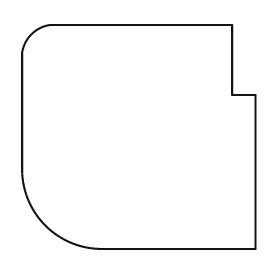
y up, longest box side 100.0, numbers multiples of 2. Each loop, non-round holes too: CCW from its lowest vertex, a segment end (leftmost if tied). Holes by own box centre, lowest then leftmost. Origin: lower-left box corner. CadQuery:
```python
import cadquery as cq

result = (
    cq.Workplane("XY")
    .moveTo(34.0, 0.0)
    .lineTo(100.0, 0.0)
    .lineTo(100.0, 66.0)
    .lineTo(90.0, 66.0)
    .lineTo(90.0, 96.0)
    .lineTo(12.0, 96.0)
    .threePointArc((4.0, 92.0), (0.0, 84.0))
    .lineTo(0.0, 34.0)
    .threePointArc((10.0, 10.0), (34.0, 0.0))
    .close()
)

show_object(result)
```